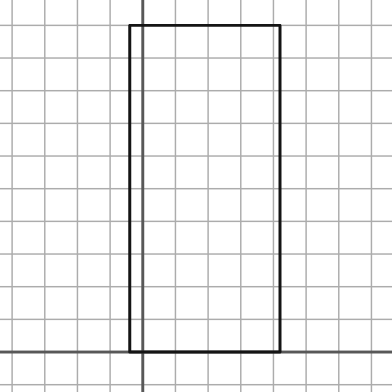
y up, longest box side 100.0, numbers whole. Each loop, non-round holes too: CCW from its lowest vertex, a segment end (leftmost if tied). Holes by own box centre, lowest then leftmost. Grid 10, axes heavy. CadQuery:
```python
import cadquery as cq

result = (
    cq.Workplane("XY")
    .moveTo(-4.0, 0.0)
    .lineTo(42.0, 0.0)
    .lineTo(42.0, 100.0)
    .lineTo(-4.0, 100.0)
    .close()
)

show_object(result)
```